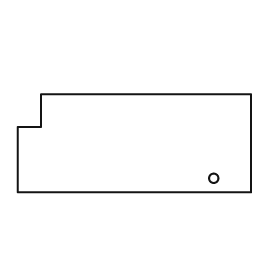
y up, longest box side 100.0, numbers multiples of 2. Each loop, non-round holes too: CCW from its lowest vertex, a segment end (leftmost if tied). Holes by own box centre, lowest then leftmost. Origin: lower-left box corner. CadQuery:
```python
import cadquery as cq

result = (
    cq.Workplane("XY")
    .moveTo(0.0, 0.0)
    .lineTo(100.0, 0.0)
    .lineTo(100.0, 42.0)
    .lineTo(10.0, 42.0)
    .lineTo(10.0, 28.0)
    .lineTo(0.0, 28.0)
    .close()
    .moveTo(84.0, 6.0)
    .circle(2.0)
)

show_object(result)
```